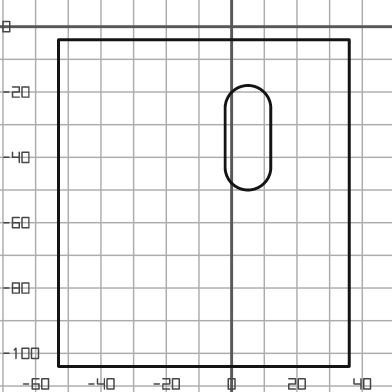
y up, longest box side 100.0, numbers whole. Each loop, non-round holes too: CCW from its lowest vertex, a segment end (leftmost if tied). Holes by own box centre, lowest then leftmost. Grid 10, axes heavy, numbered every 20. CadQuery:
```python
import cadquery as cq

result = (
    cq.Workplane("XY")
    .moveTo(-53.0, -104.0)
    .lineTo(36.0, -104.0)
    .lineTo(36.0, -4.0)
    .lineTo(-53.0, -4.0)
    .close()
    .moveTo(-2.0, -43.0)
    .threePointArc((5.0, -50.0), (12.0, -43.0))
    .lineTo(12.0, -25.0)
    .threePointArc((5.0, -18.0), (-2.0, -25.0))
    .close()
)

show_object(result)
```